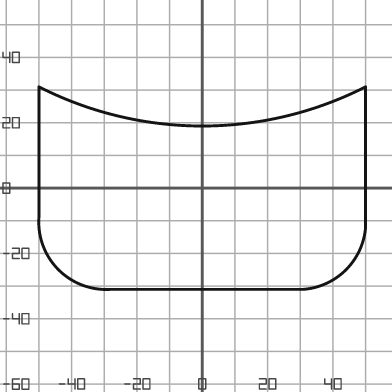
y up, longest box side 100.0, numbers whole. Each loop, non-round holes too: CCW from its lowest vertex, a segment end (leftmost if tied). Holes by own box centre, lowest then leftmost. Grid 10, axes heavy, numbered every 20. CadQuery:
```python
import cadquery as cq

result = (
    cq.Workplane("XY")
    .moveTo(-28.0, -31.0)
    .lineTo(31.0, -31.0)
    .threePointArc((44.0, -25.0), (50.0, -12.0))
    .lineTo(50.0, 31.0)
    .threePointArc((0.0, 19.0), (-50.0, 31.0))
    .lineTo(-50.0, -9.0)
    .threePointArc((-44.0, -25.0), (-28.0, -31.0))
    .close()
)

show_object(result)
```